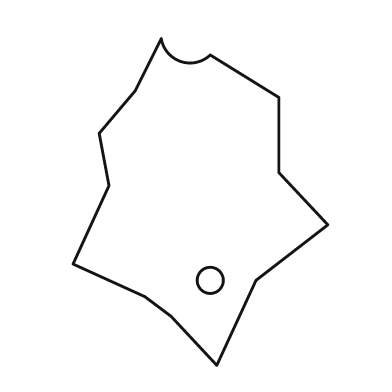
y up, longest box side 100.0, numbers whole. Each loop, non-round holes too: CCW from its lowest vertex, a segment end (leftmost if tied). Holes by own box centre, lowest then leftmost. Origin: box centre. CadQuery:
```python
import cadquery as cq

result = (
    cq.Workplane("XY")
    .moveTo(5.0, -50.0)
    .lineTo(17.0, -24.0)
    .lineTo(39.0, -7.0)
    .lineTo(24.0, 9.0)
    .lineTo(24.0, 32.0)
    .lineTo(3.0, 45.0)
    .threePointArc((-6.0, 43.0), (-12.0, 50.0))
    .lineTo(-20.0, 34.0)
    .lineTo(-31.0, 21.0)
    .lineTo(-28.0, 5.0)
    .lineTo(-39.0, -19.0)
    .lineTo(-17.0, -29.0)
    .lineTo(-9.0, -35.0)
    .close()
    .moveTo(3.0, -24.0)
    .circle(4.0)
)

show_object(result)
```